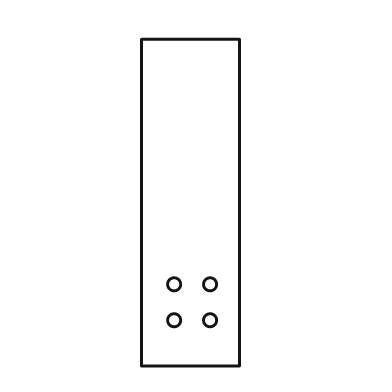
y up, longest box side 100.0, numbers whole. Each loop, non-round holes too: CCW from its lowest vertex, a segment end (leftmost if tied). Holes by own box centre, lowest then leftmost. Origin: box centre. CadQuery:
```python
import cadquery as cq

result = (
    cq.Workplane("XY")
    .moveTo(-15.0, -50.0)
    .lineTo(15.0, -50.0)
    .lineTo(15.0, 50.0)
    .lineTo(-15.0, 50.0)
    .close()
    .moveTo(-5.0, -36.0)
    .circle(2.0)
    .moveTo(6.0, -36.0)
    .circle(2.0)
    .moveTo(-5.0, -25.0)
    .circle(2.0)
    .moveTo(6.0, -25.0)
    .circle(2.0)
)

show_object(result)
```